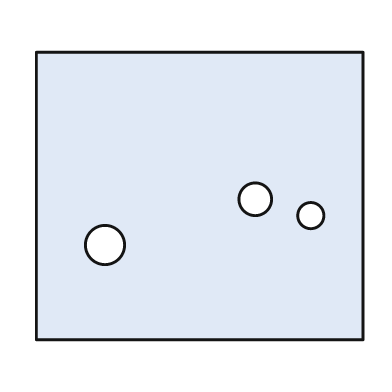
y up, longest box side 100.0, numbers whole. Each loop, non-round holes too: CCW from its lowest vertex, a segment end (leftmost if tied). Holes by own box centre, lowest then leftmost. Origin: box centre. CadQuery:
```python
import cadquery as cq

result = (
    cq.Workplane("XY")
    .moveTo(-50.0, -44.0)
    .lineTo(50.0, -44.0)
    .lineTo(50.0, 44.0)
    .lineTo(-50.0, 44.0)
    .close()
    .moveTo(-29.0, -15.0)
    .circle(6.0)
    .moveTo(34.0, -6.0)
    .circle(4.0)
    .moveTo(17.0, -1.0)
    .circle(5.0)
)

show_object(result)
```